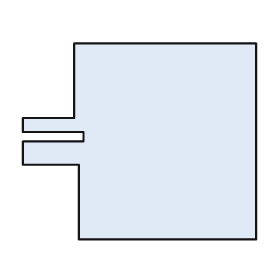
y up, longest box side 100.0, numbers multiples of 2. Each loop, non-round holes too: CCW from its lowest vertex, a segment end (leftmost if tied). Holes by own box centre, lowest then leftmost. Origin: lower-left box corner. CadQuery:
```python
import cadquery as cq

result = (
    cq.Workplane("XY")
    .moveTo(24.0, 0.0)
    .lineTo(100.0, 0.0)
    .lineTo(100.0, 84.0)
    .lineTo(22.0, 84.0)
    .lineTo(22.0, 52.0)
    .lineTo(0.0, 52.0)
    .lineTo(0.0, 46.0)
    .lineTo(26.0, 46.0)
    .lineTo(26.0, 42.0)
    .lineTo(0.0, 42.0)
    .lineTo(0.0, 32.0)
    .lineTo(24.0, 32.0)
    .close()
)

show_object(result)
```